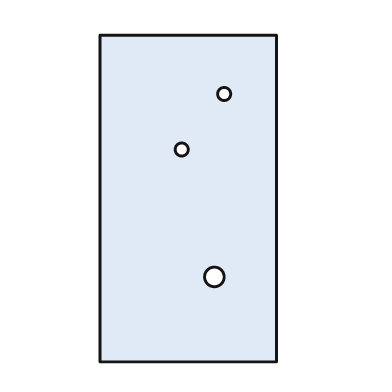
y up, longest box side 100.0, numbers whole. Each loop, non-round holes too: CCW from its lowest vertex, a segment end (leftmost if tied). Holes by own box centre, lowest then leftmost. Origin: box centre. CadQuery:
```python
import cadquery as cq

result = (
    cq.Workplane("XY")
    .moveTo(-27.0, -50.0)
    .lineTo(27.0, -50.0)
    .lineTo(27.0, 50.0)
    .lineTo(-27.0, 50.0)
    .close()
    .moveTo(8.0, -24.0)
    .circle(3.0)
    .moveTo(-2.0, 15.0)
    .circle(2.0)
    .moveTo(11.0, 32.0)
    .circle(2.0)
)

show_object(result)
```